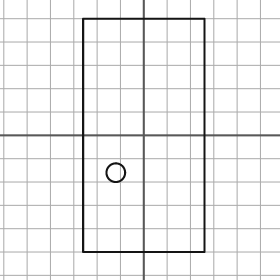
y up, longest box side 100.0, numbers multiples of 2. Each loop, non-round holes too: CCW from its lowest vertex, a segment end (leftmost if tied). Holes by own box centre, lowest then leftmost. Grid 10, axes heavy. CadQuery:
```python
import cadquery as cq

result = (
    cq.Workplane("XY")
    .moveTo(-26.0, -50.0)
    .lineTo(26.0, -50.0)
    .lineTo(26.0, 50.0)
    .lineTo(-26.0, 50.0)
    .close()
    .moveTo(-12.0, -16.0)
    .circle(4.0)
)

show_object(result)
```